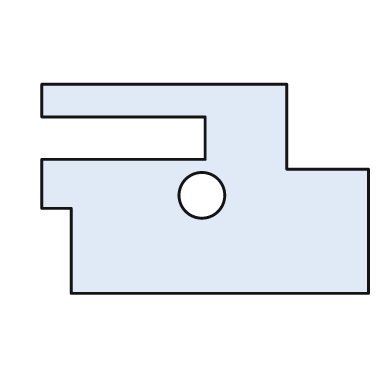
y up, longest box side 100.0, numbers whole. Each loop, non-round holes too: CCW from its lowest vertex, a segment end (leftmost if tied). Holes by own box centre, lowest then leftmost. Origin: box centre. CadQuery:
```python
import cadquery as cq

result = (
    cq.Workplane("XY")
    .moveTo(-41.0, -32.0)
    .lineTo(50.0, -32.0)
    .lineTo(50.0, 6.0)
    .lineTo(25.0, 6.0)
    .lineTo(25.0, 32.0)
    .lineTo(-50.0, 32.0)
    .lineTo(-50.0, 22.0)
    .lineTo(0.0, 22.0)
    .lineTo(0.0, 9.0)
    .lineTo(-50.0, 9.0)
    .lineTo(-50.0, -6.0)
    .lineTo(-41.0, -6.0)
    .close()
    .moveTo(-1.0, -2.0)
    .circle(7.0)
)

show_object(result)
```